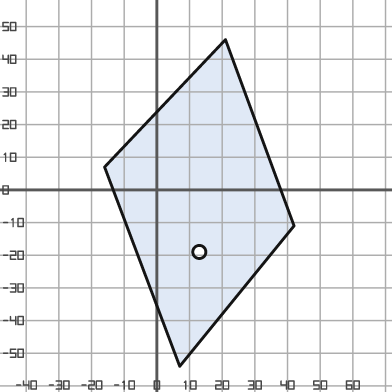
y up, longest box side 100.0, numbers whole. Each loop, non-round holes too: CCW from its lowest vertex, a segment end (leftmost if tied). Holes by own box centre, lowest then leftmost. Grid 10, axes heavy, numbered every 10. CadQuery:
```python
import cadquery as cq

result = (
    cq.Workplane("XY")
    .moveTo(7.0, -54.0)
    .lineTo(42.0, -11.0)
    .lineTo(21.0, 46.0)
    .lineTo(-16.0, 7.0)
    .close()
    .moveTo(13.0, -19.0)
    .circle(2.0)
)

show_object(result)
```